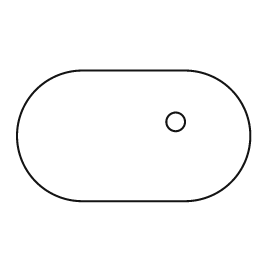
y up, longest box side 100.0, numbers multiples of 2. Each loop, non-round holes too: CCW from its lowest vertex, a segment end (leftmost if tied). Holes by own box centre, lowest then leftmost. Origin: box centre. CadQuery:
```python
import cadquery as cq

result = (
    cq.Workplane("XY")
    .moveTo(-22.0, -28.0)
    .lineTo(22.0, -28.0)
    .threePointArc((50.0, 0.0), (22.0, 28.0))
    .lineTo(-22.0, 28.0)
    .threePointArc((-50.0, 0.0), (-22.0, -28.0))
    .close()
    .moveTo(18.0, 6.0)
    .circle(4.0)
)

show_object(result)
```